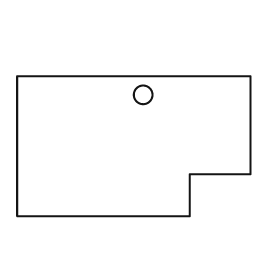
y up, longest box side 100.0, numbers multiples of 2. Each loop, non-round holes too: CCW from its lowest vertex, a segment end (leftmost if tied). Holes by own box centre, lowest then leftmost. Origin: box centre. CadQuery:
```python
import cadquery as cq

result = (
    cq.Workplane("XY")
    .moveTo(-50.0, -30.0)
    .lineTo(24.0, -30.0)
    .lineTo(24.0, -12.0)
    .lineTo(50.0, -12.0)
    .lineTo(50.0, 30.0)
    .lineTo(-50.0, 30.0)
    .close()
    .moveTo(4.0, 22.0)
    .circle(4.0)
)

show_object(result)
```